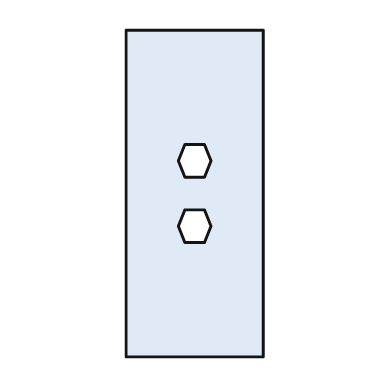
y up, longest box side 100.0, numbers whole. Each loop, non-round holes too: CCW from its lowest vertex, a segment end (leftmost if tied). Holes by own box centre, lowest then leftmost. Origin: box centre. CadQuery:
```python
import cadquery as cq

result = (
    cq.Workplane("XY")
    .moveTo(-21.0, -50.0)
    .lineTo(21.0, -50.0)
    .lineTo(21.0, 50.0)
    .lineTo(-21.0, 50.0)
    .close()
    .moveTo(-3.0, -15.0)
    .lineTo(3.0, -15.0)
    .lineTo(5.0, -10.0)
    .lineTo(3.0, -5.0)
    .lineTo(-3.0, -5.0)
    .lineTo(-5.0, -10.0)
    .close()
    .moveTo(-3.0, 5.0)
    .lineTo(3.0, 5.0)
    .lineTo(5.0, 10.0)
    .lineTo(3.0, 15.0)
    .lineTo(-3.0, 15.0)
    .lineTo(-5.0, 10.0)
    .close()
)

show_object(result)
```